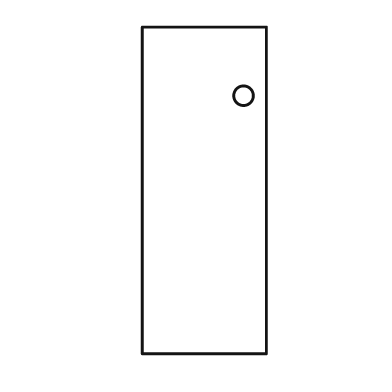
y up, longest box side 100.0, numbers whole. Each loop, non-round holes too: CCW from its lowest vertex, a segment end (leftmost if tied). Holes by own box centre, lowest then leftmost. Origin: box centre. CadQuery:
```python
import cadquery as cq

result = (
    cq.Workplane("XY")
    .moveTo(-19.0, -50.0)
    .lineTo(19.0, -50.0)
    .lineTo(19.0, 50.0)
    .lineTo(-19.0, 50.0)
    .close()
    .moveTo(12.0, 29.0)
    .circle(3.0)
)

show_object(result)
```